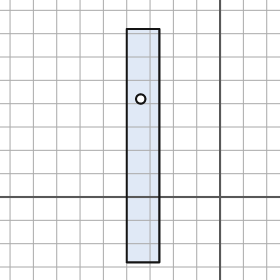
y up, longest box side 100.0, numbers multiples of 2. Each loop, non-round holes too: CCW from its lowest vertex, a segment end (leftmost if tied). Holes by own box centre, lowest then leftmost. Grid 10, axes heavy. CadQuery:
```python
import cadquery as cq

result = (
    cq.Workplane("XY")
    .moveTo(-40.0, -28.0)
    .lineTo(-26.0, -28.0)
    .lineTo(-26.0, 72.0)
    .lineTo(-40.0, 72.0)
    .close()
    .moveTo(-34.0, 42.0)
    .circle(2.0)
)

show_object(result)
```